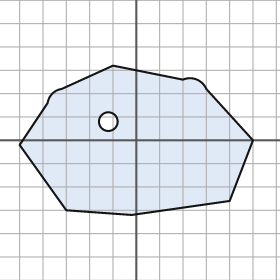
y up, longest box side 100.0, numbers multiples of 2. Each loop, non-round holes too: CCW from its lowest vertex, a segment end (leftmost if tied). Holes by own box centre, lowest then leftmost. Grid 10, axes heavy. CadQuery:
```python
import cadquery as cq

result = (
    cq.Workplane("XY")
    .moveTo(-2.0, -32.0)
    .lineTo(40.0, -26.0)
    .lineTo(50.0, 0.0)
    .lineTo(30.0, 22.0)
    .threePointArc((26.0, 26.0), (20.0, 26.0))
    .lineTo(-10.0, 32.0)
    .lineTo(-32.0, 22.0)
    .threePointArc((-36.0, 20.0), (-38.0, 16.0))
    .lineTo(-50.0, -2.0)
    .lineTo(-30.0, -30.0)
    .close()
    .moveTo(-12.0, 8.0)
    .circle(4.0)
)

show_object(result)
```